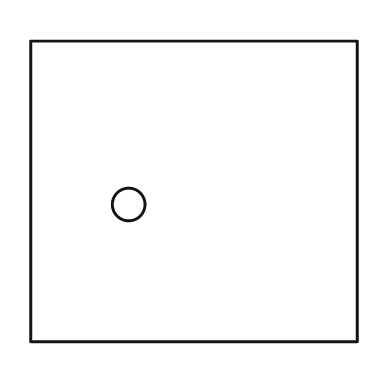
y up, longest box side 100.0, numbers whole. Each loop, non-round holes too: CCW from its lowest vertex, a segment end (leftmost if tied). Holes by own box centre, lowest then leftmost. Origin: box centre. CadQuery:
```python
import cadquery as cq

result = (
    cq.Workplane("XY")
    .moveTo(-50.0, -46.0)
    .lineTo(50.0, -46.0)
    .lineTo(50.0, 46.0)
    .lineTo(-50.0, 46.0)
    .close()
    .moveTo(-20.0, -4.0)
    .circle(5.0)
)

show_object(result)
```